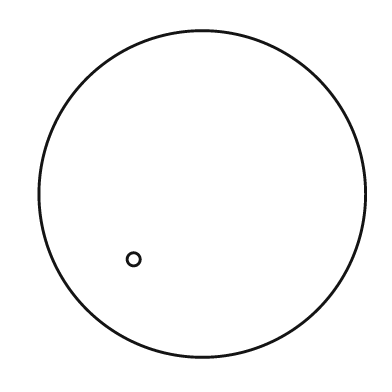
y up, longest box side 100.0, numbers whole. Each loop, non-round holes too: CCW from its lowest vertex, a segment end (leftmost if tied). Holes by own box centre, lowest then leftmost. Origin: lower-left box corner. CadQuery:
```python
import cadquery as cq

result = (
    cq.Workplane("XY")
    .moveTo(50.0, 50.0)
    .circle(50.0)
    .moveTo(29.0, 30.0)
    .circle(2.0)
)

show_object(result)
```